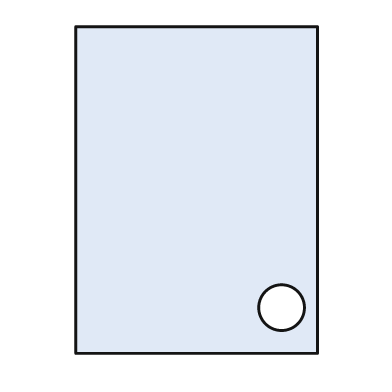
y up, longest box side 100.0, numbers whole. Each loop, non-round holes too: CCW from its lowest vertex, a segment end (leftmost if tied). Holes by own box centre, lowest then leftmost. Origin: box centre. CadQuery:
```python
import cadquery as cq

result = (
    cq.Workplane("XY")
    .moveTo(-37.0, -50.0)
    .lineTo(37.0, -50.0)
    .lineTo(37.0, 50.0)
    .lineTo(-37.0, 50.0)
    .close()
    .moveTo(26.0, -36.0)
    .circle(7.0)
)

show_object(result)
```